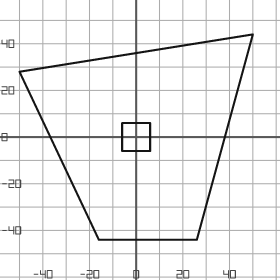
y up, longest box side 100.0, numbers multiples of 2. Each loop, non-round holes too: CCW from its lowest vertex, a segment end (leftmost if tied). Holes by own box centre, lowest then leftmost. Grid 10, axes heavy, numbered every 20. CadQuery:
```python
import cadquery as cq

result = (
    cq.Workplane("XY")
    .moveTo(-16.0, -44.0)
    .lineTo(26.0, -44.0)
    .lineTo(50.0, 44.0)
    .lineTo(-50.0, 28.0)
    .close()
    .moveTo(-6.0, -6.0)
    .lineTo(6.0, -6.0)
    .lineTo(6.0, 6.0)
    .lineTo(-6.0, 6.0)
    .close()
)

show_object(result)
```